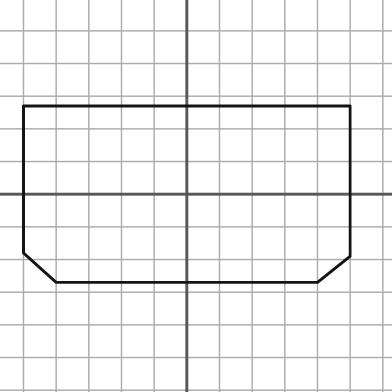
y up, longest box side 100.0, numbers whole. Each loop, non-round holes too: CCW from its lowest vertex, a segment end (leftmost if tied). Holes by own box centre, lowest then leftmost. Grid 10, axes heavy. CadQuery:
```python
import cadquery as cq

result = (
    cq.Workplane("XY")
    .moveTo(-40.0, -27.0)
    .lineTo(40.0, -27.0)
    .lineTo(50.0, -19.0)
    .lineTo(50.0, 27.0)
    .lineTo(-50.0, 27.0)
    .lineTo(-50.0, -18.0)
    .close()
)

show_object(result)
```